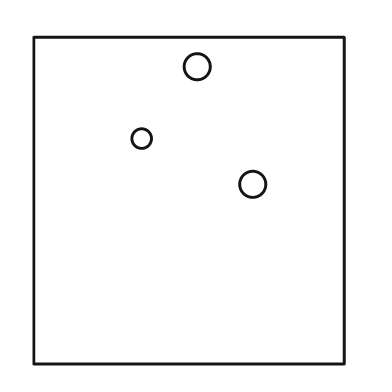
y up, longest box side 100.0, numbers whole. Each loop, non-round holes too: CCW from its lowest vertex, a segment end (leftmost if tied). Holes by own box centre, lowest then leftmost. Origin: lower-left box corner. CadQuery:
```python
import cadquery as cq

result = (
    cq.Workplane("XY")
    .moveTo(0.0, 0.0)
    .lineTo(95.0, 0.0)
    .lineTo(95.0, 100.0)
    .lineTo(0.0, 100.0)
    .close()
    .moveTo(67.0, 55.0)
    .circle(4.0)
    .moveTo(33.0, 69.0)
    .circle(3.0)
    .moveTo(50.0, 91.0)
    .circle(4.0)
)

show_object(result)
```